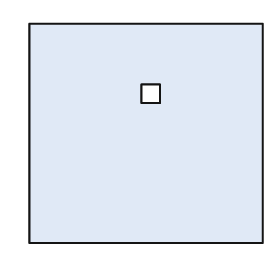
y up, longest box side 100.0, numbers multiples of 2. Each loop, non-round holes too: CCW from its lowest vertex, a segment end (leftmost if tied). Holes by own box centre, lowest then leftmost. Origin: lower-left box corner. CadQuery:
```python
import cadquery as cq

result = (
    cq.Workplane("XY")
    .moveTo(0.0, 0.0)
    .lineTo(100.0, 0.0)
    .lineTo(100.0, 94.0)
    .lineTo(0.0, 94.0)
    .close()
    .moveTo(48.0, 60.0)
    .lineTo(56.0, 60.0)
    .lineTo(56.0, 68.0)
    .lineTo(48.0, 68.0)
    .close()
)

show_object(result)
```